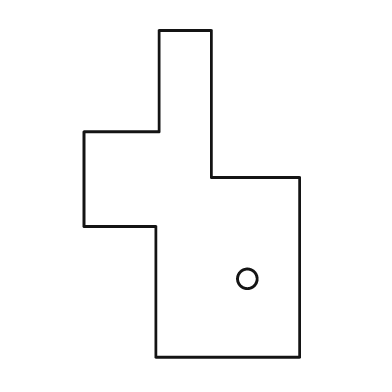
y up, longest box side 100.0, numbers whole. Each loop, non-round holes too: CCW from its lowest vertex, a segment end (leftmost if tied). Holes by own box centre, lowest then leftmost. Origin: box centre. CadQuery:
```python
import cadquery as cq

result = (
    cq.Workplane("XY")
    .moveTo(-11.0, -50.0)
    .lineTo(33.0, -50.0)
    .lineTo(33.0, 5.0)
    .lineTo(6.0, 5.0)
    .lineTo(6.0, 50.0)
    .lineTo(-10.0, 50.0)
    .lineTo(-10.0, 19.0)
    .lineTo(-33.0, 19.0)
    .lineTo(-33.0, -10.0)
    .lineTo(-11.0, -10.0)
    .close()
    .moveTo(17.0, -26.0)
    .circle(3.0)
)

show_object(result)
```